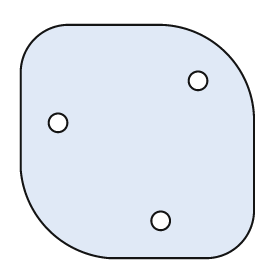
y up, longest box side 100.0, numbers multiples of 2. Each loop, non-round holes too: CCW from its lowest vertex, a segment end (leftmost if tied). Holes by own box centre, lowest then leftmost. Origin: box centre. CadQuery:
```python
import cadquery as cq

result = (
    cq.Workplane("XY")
    .moveTo(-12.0, -50.0)
    .lineTo(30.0, -50.0)
    .threePointArc((44.0, -44.0), (50.0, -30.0))
    .lineTo(50.0, 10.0)
    .threePointArc((38.0, 38.0), (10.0, 50.0))
    .lineTo(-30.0, 50.0)
    .threePointArc((-44.0, 44.0), (-50.0, 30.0))
    .lineTo(-50.0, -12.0)
    .threePointArc((-38.0, -38.0), (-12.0, -50.0))
    .close()
    .moveTo(10.0, -34.0)
    .circle(4.0)
    .moveTo(-34.0, 8.0)
    .circle(4.0)
    .moveTo(26.0, 26.0)
    .circle(4.0)
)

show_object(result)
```